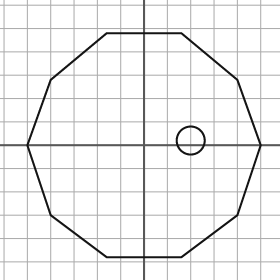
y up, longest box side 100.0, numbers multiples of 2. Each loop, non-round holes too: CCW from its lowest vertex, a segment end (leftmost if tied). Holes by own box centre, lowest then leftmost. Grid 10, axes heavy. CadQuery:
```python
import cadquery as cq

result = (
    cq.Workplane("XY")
    .moveTo(-16.0, -48.0)
    .lineTo(16.0, -48.0)
    .lineTo(40.0, -30.0)
    .lineTo(50.0, 0.0)
    .lineTo(40.0, 28.0)
    .lineTo(16.0, 48.0)
    .lineTo(-16.0, 48.0)
    .lineTo(-40.0, 28.0)
    .lineTo(-50.0, 0.0)
    .lineTo(-40.0, -30.0)
    .close()
    .moveTo(20.0, 2.0)
    .circle(6.0)
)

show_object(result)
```